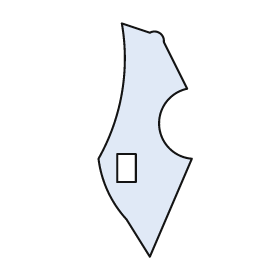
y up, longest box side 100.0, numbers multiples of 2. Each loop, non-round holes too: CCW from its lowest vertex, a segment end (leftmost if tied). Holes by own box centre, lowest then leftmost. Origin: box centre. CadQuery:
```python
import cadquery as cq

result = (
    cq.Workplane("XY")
    .moveTo(2.0, -50.0)
    .lineTo(20.0, -8.0)
    .threePointArc((6.0, 6.0), (18.0, 22.0))
    .lineTo(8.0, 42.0)
    .threePointArc((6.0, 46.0), (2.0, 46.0))
    .lineTo(-10.0, 50.0)
    .threePointArc((-10.0, 20.0), (-20.0, -8.0))
    .threePointArc((-16.0, -22.0), (-8.0, -34.0))
    .close()
    .moveTo(-12.0, -18.0)
    .lineTo(-4.0, -18.0)
    .lineTo(-4.0, -6.0)
    .lineTo(-12.0, -6.0)
    .close()
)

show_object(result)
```